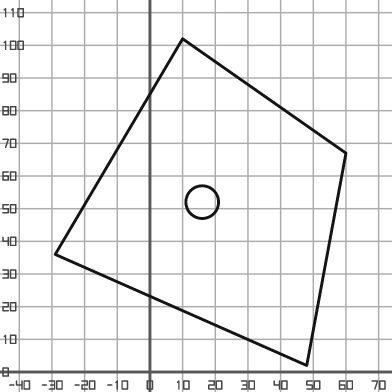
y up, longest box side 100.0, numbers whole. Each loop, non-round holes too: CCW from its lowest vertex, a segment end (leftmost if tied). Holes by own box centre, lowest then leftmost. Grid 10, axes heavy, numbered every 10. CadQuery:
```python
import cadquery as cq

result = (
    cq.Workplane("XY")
    .moveTo(48.0, 2.0)
    .lineTo(60.0, 67.0)
    .lineTo(10.0, 102.0)
    .lineTo(-29.0, 36.0)
    .close()
    .moveTo(16.0, 52.0)
    .circle(5.0)
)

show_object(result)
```